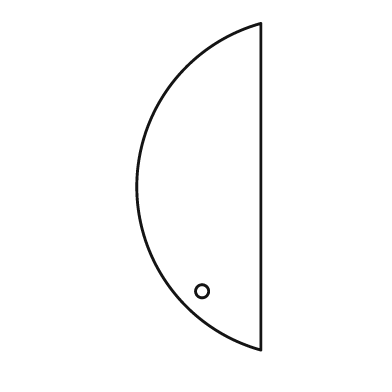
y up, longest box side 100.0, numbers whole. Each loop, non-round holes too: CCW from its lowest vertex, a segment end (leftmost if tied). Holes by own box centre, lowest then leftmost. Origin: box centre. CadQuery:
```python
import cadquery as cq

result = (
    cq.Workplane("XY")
    .moveTo(19.0, -50.0)
    .lineTo(19.0, 50.0)
    .threePointArc((-19.0, 0.0), (19.0, -50.0))
    .close()
    .moveTo(1.0, -32.0)
    .circle(2.0)
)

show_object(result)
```